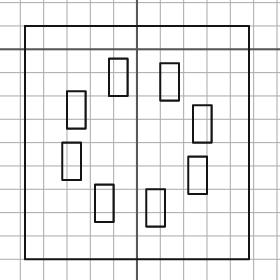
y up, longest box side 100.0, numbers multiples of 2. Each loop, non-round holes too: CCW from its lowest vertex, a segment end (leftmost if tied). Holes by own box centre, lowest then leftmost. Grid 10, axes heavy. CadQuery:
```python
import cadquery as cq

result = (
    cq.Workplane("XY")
    .moveTo(-48.0, -90.0)
    .lineTo(48.0, -90.0)
    .lineTo(48.0, 10.0)
    .lineTo(-48.0, 10.0)
    .close()
    .moveTo(4.0, -76.0)
    .lineTo(12.0, -76.0)
    .lineTo(12.0, -60.0)
    .lineTo(4.0, -60.0)
    .close()
    .moveTo(-18.0, -74.0)
    .lineTo(-10.0, -74.0)
    .lineTo(-10.0, -58.0)
    .lineTo(-18.0, -58.0)
    .close()
    .moveTo(22.0, -62.0)
    .lineTo(30.0, -62.0)
    .lineTo(30.0, -46.0)
    .lineTo(22.0, -46.0)
    .close()
    .moveTo(-32.0, -56.0)
    .lineTo(-24.0, -56.0)
    .lineTo(-24.0, -40.0)
    .lineTo(-32.0, -40.0)
    .close()
    .moveTo(24.0, -40.0)
    .lineTo(32.0, -40.0)
    .lineTo(32.0, -24.0)
    .lineTo(24.0, -24.0)
    .close()
    .moveTo(-30.0, -34.0)
    .lineTo(-22.0, -34.0)
    .lineTo(-22.0, -18.0)
    .lineTo(-30.0, -18.0)
    .close()
    .moveTo(10.0, -22.0)
    .lineTo(18.0, -22.0)
    .lineTo(18.0, -6.0)
    .lineTo(10.0, -6.0)
    .close()
    .moveTo(-12.0, -20.0)
    .lineTo(-4.0, -20.0)
    .lineTo(-4.0, -4.0)
    .lineTo(-12.0, -4.0)
    .close()
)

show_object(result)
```